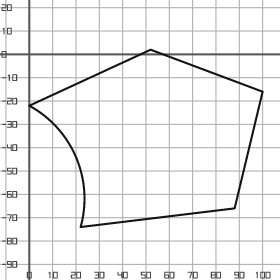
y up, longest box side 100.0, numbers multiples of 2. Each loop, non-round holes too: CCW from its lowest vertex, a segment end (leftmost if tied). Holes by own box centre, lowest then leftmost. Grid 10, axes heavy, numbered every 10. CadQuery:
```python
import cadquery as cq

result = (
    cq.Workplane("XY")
    .moveTo(22.0, -74.0)
    .lineTo(88.0, -66.0)
    .lineTo(100.0, -16.0)
    .lineTo(52.0, 2.0)
    .lineTo(0.0, -22.0)
    .threePointArc((20.0, -44.0), (22.0, -74.0))
    .close()
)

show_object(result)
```